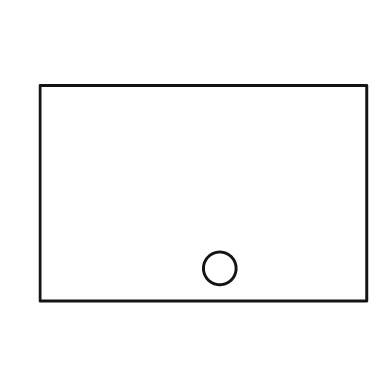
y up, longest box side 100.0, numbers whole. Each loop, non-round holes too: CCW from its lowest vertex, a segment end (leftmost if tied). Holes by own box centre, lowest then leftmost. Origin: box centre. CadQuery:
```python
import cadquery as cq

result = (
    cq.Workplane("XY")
    .moveTo(-50.0, -33.0)
    .lineTo(50.0, -33.0)
    .lineTo(50.0, 33.0)
    .lineTo(-50.0, 33.0)
    .close()
    .moveTo(5.0, -23.0)
    .circle(5.0)
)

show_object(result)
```